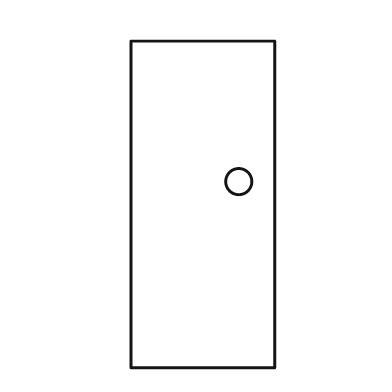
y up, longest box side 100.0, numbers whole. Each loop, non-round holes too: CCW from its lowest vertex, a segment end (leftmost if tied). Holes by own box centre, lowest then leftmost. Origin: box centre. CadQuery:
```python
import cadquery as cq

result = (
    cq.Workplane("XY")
    .moveTo(-22.0, -50.0)
    .lineTo(22.0, -50.0)
    .lineTo(22.0, 50.0)
    .lineTo(-22.0, 50.0)
    .close()
    .moveTo(11.0, 7.0)
    .circle(4.0)
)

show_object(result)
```